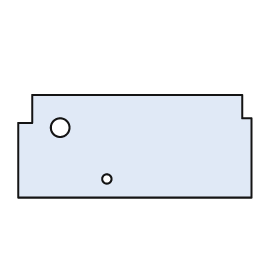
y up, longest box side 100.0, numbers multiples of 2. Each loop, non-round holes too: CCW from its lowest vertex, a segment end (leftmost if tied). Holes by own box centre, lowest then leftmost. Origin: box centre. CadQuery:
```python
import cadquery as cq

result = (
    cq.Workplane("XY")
    .moveTo(-50.0, -22.0)
    .lineTo(50.0, -22.0)
    .lineTo(50.0, 12.0)
    .lineTo(46.0, 12.0)
    .lineTo(46.0, 22.0)
    .lineTo(-44.0, 22.0)
    .lineTo(-44.0, 10.0)
    .lineTo(-50.0, 10.0)
    .close()
    .moveTo(-12.0, -14.0)
    .circle(2.0)
    .moveTo(-32.0, 8.0)
    .circle(4.0)
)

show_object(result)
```